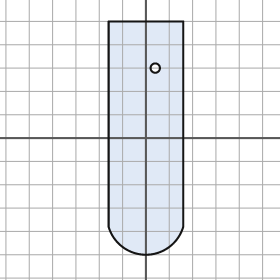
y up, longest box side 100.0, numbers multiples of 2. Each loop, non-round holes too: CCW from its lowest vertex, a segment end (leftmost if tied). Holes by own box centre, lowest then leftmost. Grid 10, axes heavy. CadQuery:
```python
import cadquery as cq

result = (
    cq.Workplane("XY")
    .moveTo(-16.0, -38.0)
    .threePointArc((0.0, -50.0), (16.0, -38.0))
    .lineTo(16.0, 50.0)
    .lineTo(-16.0, 50.0)
    .close()
    .moveTo(4.0, 30.0)
    .circle(2.0)
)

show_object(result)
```